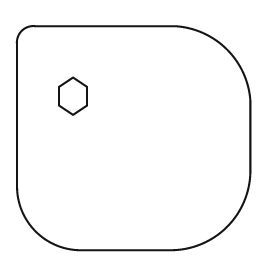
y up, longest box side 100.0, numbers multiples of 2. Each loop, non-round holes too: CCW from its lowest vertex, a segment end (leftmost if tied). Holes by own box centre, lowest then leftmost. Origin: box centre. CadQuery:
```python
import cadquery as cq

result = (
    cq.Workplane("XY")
    .moveTo(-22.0, -48.0)
    .lineTo(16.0, -48.0)
    .threePointArc((40.0, -38.0), (50.0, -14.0))
    .lineTo(50.0, 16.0)
    .threePointArc((40.0, 38.0), (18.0, 48.0))
    .lineTo(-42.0, 48.0)
    .threePointArc((-48.0, 46.0), (-50.0, 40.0))
    .lineTo(-50.0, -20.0)
    .threePointArc((-42.0, -40.0), (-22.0, -48.0))
    .close()
    .moveTo(-26.0, 10.0)
    .lineTo(-20.0, 14.0)
    .lineTo(-20.0, 22.0)
    .lineTo(-26.0, 26.0)
    .lineTo(-32.0, 22.0)
    .lineTo(-32.0, 14.0)
    .close()
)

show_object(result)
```